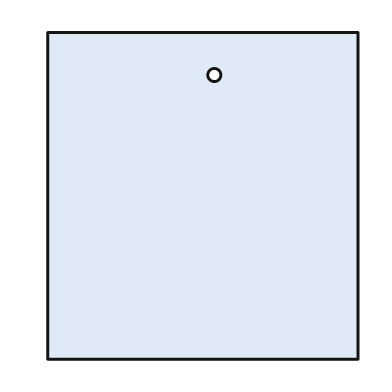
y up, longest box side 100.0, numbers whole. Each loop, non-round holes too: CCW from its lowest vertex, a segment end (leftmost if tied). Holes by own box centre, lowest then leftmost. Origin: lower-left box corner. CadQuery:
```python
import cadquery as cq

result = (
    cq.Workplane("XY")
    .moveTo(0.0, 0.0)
    .lineTo(95.0, 0.0)
    .lineTo(95.0, 100.0)
    .lineTo(0.0, 100.0)
    .close()
    .moveTo(51.0, 87.0)
    .circle(2.0)
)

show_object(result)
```